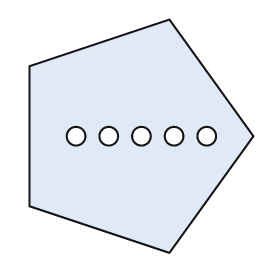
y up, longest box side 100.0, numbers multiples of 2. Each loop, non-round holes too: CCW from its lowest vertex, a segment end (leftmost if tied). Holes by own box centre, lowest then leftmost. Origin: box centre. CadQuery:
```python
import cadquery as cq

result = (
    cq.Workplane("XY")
    .moveTo(12.0, -50.0)
    .lineTo(48.0, 0.0)
    .lineTo(12.0, 50.0)
    .lineTo(-48.0, 30.0)
    .lineTo(-48.0, -30.0)
    .close()
    .moveTo(-28.0, 0.0)
    .circle(4.0)
    .moveTo(-14.0, 0.0)
    .circle(4.0)
    .moveTo(0.0, 0.0)
    .circle(4.0)
    .moveTo(14.0, 0.0)
    .circle(4.0)
    .moveTo(28.0, 0.0)
    .circle(4.0)
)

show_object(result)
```